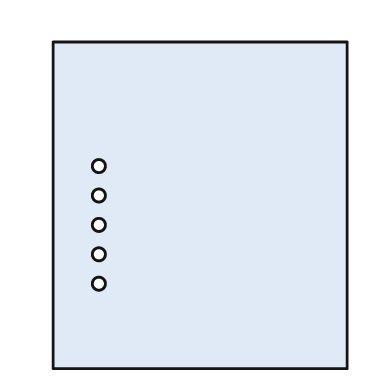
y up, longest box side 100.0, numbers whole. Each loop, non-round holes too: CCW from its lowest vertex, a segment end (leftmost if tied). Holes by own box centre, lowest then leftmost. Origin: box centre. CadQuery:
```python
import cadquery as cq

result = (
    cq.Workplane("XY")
    .moveTo(-45.0, -50.0)
    .lineTo(45.0, -50.0)
    .lineTo(45.0, 50.0)
    .lineTo(-45.0, 50.0)
    .close()
    .moveTo(-31.0, -24.0)
    .circle(2.0)
    .moveTo(-31.0, -15.0)
    .circle(2.0)
    .moveTo(-31.0, -6.0)
    .circle(2.0)
    .moveTo(-31.0, 3.0)
    .circle(2.0)
    .moveTo(-31.0, 12.0)
    .circle(2.0)
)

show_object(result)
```